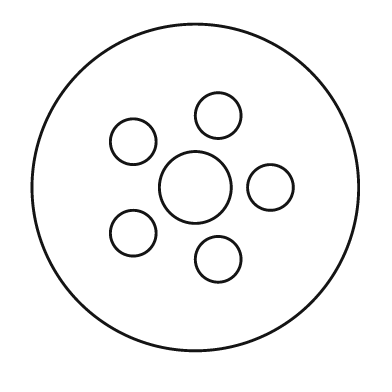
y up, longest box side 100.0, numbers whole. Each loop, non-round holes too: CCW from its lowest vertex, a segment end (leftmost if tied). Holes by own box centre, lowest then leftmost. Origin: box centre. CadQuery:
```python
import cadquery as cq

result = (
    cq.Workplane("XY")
    .moveTo(0.0, 0.0)
    .circle(50.0)
    .moveTo(7.0, -22.0)
    .circle(7.0)
    .moveTo(-19.0, -14.0)
    .circle(7.0)
    .moveTo(0.0, 0.0)
    .circle(11.0)
    .moveTo(23.0, 0.0)
    .circle(7.0)
    .moveTo(-19.0, 14.0)
    .circle(7.0)
    .moveTo(7.0, 22.0)
    .circle(7.0)
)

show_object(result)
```